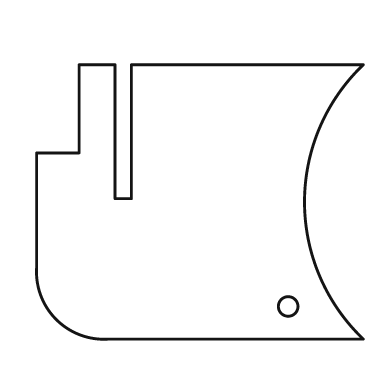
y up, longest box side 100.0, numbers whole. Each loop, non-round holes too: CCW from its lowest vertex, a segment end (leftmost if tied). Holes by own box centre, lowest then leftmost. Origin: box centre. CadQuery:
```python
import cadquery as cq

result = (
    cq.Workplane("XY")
    .moveTo(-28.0, -42.0)
    .lineTo(50.0, -42.0)
    .threePointArc((32.0, 0.0), (50.0, 42.0))
    .lineTo(-21.0, 42.0)
    .lineTo(-21.0, 1.0)
    .lineTo(-26.0, 1.0)
    .lineTo(-26.0, 42.0)
    .lineTo(-37.0, 42.0)
    .lineTo(-37.0, 15.0)
    .lineTo(-50.0, 15.0)
    .lineTo(-50.0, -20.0)
    .threePointArc((-44.0, -36.0), (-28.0, -42.0))
    .close()
    .moveTo(27.0, -32.0)
    .circle(3.0)
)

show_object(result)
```